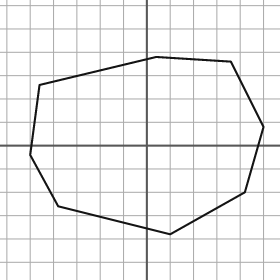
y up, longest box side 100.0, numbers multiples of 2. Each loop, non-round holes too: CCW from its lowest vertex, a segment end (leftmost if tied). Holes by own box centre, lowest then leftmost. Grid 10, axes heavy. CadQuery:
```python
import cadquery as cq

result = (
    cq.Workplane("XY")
    .moveTo(10.0, -38.0)
    .lineTo(42.0, -20.0)
    .lineTo(50.0, 8.0)
    .lineTo(36.0, 36.0)
    .lineTo(4.0, 38.0)
    .lineTo(-46.0, 26.0)
    .lineTo(-50.0, -4.0)
    .lineTo(-38.0, -26.0)
    .close()
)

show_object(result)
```